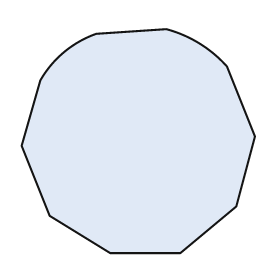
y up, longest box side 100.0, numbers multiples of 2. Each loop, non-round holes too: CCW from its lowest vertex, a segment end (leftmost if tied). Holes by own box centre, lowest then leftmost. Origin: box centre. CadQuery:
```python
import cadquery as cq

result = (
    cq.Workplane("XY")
    .moveTo(-12.0, -48.0)
    .lineTo(18.0, -48.0)
    .lineTo(42.0, -28.0)
    .lineTo(50.0, 2.0)
    .lineTo(38.0, 32.0)
    .threePointArc((26.0, 42.0), (12.0, 48.0))
    .lineTo(-18.0, 46.0)
    .threePointArc((-32.0, 38.0), (-42.0, 26.0))
    .lineTo(-50.0, -2.0)
    .lineTo(-38.0, -32.0)
    .close()
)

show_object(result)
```